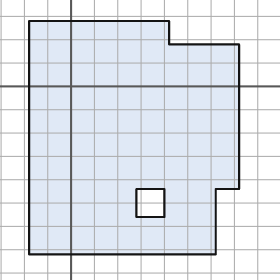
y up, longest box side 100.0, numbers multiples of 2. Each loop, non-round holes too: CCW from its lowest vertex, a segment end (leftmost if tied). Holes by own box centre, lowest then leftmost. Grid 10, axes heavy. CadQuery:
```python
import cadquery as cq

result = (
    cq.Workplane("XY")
    .moveTo(-18.0, -72.0)
    .lineTo(62.0, -72.0)
    .lineTo(62.0, -44.0)
    .lineTo(72.0, -44.0)
    .lineTo(72.0, 18.0)
    .lineTo(42.0, 18.0)
    .lineTo(42.0, 28.0)
    .lineTo(-18.0, 28.0)
    .close()
    .moveTo(28.0, -56.0)
    .lineTo(40.0, -56.0)
    .lineTo(40.0, -44.0)
    .lineTo(28.0, -44.0)
    .close()
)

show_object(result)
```